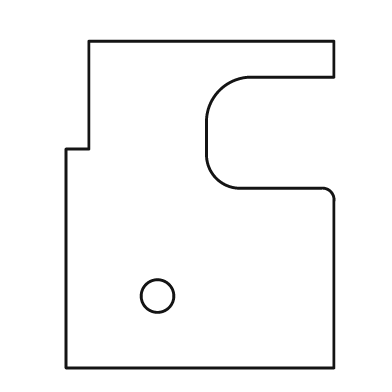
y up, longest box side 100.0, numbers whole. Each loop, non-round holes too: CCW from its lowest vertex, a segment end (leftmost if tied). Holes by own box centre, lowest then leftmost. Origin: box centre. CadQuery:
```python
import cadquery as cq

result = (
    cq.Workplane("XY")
    .moveTo(-41.0, -50.0)
    .lineTo(41.0, -50.0)
    .lineTo(41.0, 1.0)
    .threePointArc((40.0, 4.0), (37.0, 5.0))
    .lineTo(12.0, 5.0)
    .threePointArc((5.0, 8.0), (2.0, 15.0))
    .lineTo(2.0, 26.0)
    .threePointArc((6.0, 35.0), (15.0, 39.0))
    .lineTo(41.0, 39.0)
    .lineTo(41.0, 50.0)
    .lineTo(-34.0, 50.0)
    .lineTo(-34.0, 17.0)
    .lineTo(-41.0, 17.0)
    .close()
    .moveTo(-13.0, -28.0)
    .circle(5.0)
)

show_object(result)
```